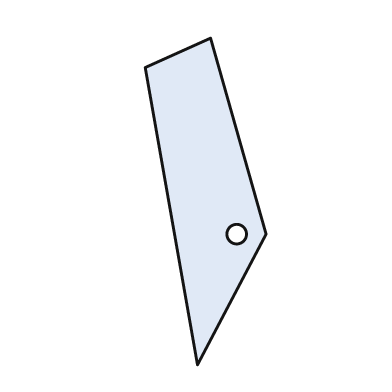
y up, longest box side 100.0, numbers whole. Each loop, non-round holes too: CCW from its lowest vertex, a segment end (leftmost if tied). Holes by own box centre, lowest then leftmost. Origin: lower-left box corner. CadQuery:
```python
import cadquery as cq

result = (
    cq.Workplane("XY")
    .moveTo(16.0, 0.0)
    .lineTo(37.0, 40.0)
    .lineTo(20.0, 100.0)
    .lineTo(0.0, 91.0)
    .close()
    .moveTo(28.0, 40.0)
    .circle(3.0)
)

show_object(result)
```